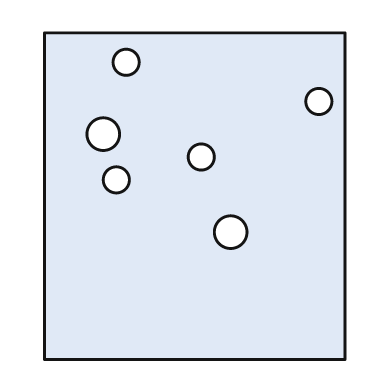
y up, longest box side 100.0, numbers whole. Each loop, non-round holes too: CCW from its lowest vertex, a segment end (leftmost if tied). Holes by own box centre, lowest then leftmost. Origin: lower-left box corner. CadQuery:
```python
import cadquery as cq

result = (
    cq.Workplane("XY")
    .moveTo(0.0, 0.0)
    .lineTo(92.0, 0.0)
    .lineTo(92.0, 100.0)
    .lineTo(0.0, 100.0)
    .close()
    .moveTo(57.0, 39.0)
    .circle(5.0)
    .moveTo(22.0, 55.0)
    .circle(4.0)
    .moveTo(48.0, 62.0)
    .circle(4.0)
    .moveTo(18.0, 69.0)
    .circle(5.0)
    .moveTo(84.0, 79.0)
    .circle(4.0)
    .moveTo(25.0, 91.0)
    .circle(4.0)
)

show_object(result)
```